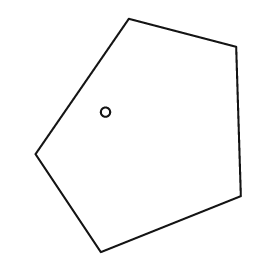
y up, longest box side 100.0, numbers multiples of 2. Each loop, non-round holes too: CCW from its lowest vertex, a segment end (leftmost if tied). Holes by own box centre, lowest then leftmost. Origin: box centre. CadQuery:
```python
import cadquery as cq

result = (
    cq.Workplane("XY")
    .moveTo(-16.0, -50.0)
    .lineTo(44.0, -26.0)
    .lineTo(42.0, 38.0)
    .lineTo(-4.0, 50.0)
    .lineTo(-44.0, -8.0)
    .close()
    .moveTo(-14.0, 10.0)
    .circle(2.0)
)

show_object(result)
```